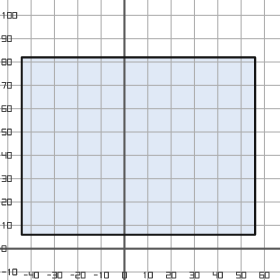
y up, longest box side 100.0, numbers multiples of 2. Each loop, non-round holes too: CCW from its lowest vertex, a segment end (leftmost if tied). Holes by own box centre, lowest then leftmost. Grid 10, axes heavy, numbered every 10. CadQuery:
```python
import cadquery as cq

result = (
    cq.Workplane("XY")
    .moveTo(-44.0, 6.0)
    .lineTo(56.0, 6.0)
    .lineTo(56.0, 82.0)
    .lineTo(-44.0, 82.0)
    .close()
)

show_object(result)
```